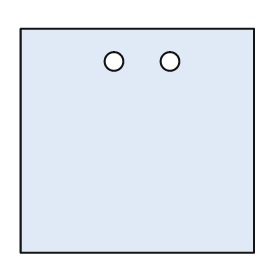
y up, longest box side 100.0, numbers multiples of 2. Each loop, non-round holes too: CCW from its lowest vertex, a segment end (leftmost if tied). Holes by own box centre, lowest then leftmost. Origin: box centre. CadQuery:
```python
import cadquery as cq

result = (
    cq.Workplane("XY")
    .moveTo(-50.0, -48.0)
    .lineTo(50.0, -48.0)
    .lineTo(50.0, 48.0)
    .lineTo(-50.0, 48.0)
    .close()
    .moveTo(-10.0, 34.0)
    .circle(4.0)
    .moveTo(14.0, 34.0)
    .circle(4.0)
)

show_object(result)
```